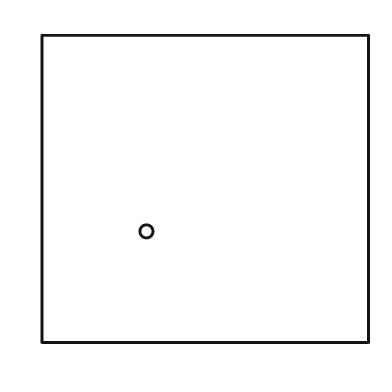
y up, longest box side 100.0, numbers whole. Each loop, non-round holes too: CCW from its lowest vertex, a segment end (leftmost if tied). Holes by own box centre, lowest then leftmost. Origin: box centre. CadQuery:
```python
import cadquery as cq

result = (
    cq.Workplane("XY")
    .moveTo(-50.0, -47.0)
    .lineTo(50.0, -47.0)
    .lineTo(50.0, 47.0)
    .lineTo(-50.0, 47.0)
    .close()
    .moveTo(-18.0, -13.0)
    .circle(2.0)
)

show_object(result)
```